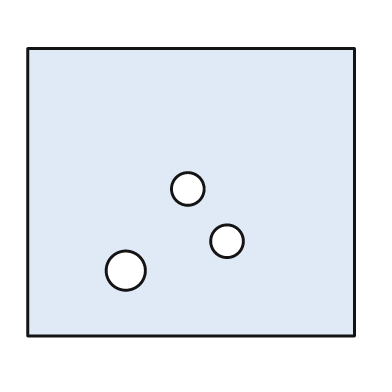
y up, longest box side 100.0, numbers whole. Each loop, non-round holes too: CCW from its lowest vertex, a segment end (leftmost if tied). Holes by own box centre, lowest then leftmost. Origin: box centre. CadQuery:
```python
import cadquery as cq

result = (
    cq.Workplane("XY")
    .moveTo(-50.0, -44.0)
    .lineTo(50.0, -44.0)
    .lineTo(50.0, 44.0)
    .lineTo(-50.0, 44.0)
    .close()
    .moveTo(-20.0, -24.0)
    .circle(6.0)
    .moveTo(11.0, -15.0)
    .circle(5.0)
    .moveTo(-1.0, 1.0)
    .circle(5.0)
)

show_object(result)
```